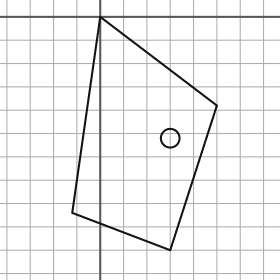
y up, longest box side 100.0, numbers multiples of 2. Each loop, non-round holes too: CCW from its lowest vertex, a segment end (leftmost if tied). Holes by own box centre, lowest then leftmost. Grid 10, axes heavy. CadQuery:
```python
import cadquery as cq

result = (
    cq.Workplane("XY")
    .moveTo(30.0, -100.0)
    .lineTo(50.0, -38.0)
    .lineTo(0.0, 0.0)
    .lineTo(-12.0, -84.0)
    .close()
    .moveTo(30.0, -52.0)
    .circle(4.0)
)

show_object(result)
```